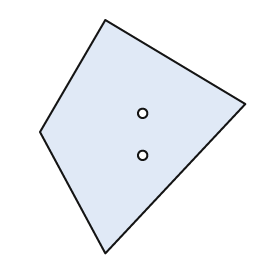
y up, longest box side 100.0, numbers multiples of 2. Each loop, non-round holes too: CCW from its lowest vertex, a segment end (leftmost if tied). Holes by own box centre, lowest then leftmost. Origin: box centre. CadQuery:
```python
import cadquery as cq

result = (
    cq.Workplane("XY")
    .moveTo(-16.0, -50.0)
    .lineTo(44.0, 14.0)
    .lineTo(-16.0, 50.0)
    .lineTo(-44.0, 2.0)
    .close()
    .moveTo(0.0, -8.0)
    .circle(2.0)
    .moveTo(0.0, 10.0)
    .circle(2.0)
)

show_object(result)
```